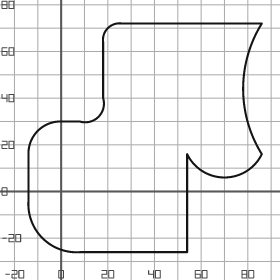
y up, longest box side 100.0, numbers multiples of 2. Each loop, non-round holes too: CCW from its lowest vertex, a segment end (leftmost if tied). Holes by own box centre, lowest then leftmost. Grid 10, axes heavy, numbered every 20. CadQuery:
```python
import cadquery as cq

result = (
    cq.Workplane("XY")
    .moveTo(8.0, -26.0)
    .lineTo(54.0, -26.0)
    .lineTo(54.0, 16.0)
    .threePointArc((70.0, 6.0), (86.0, 16.0))
    .threePointArc((78.0, 44.0), (86.0, 72.0))
    .lineTo(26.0, 72.0)
    .threePointArc((20.0, 70.0), (18.0, 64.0))
    .lineTo(18.0, 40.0)
    .threePointArc((16.0, 32.0), (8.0, 30.0))
    .lineTo(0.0, 30.0)
    .threePointArc((-10.0, 26.0), (-14.0, 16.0))
    .lineTo(-14.0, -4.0)
    .threePointArc((-8.0, -20.0), (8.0, -26.0))
    .close()
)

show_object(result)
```